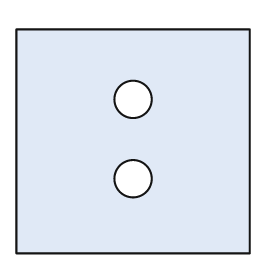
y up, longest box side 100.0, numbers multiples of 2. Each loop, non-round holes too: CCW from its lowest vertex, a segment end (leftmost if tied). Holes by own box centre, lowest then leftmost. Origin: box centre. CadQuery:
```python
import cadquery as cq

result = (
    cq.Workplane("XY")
    .moveTo(-50.0, -48.0)
    .lineTo(50.0, -48.0)
    .lineTo(50.0, 48.0)
    .lineTo(-50.0, 48.0)
    .close()
    .moveTo(0.0, -16.0)
    .circle(8.0)
    .moveTo(0.0, 18.0)
    .circle(8.0)
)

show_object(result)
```